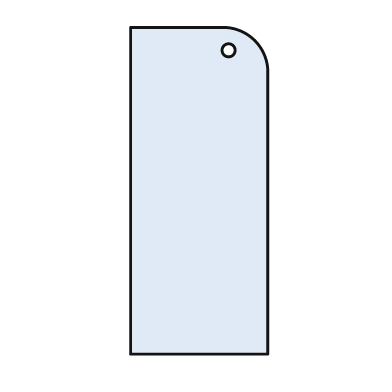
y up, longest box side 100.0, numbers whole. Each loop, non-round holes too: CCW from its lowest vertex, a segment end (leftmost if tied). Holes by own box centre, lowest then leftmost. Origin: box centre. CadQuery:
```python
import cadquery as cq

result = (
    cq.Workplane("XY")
    .moveTo(-21.0, -50.0)
    .lineTo(21.0, -50.0)
    .lineTo(21.0, 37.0)
    .threePointArc((17.0, 46.0), (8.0, 50.0))
    .lineTo(-21.0, 50.0)
    .close()
    .moveTo(9.0, 43.0)
    .circle(2.0)
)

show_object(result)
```